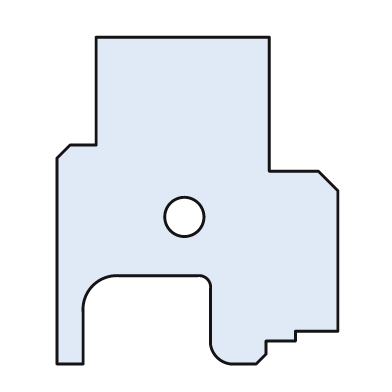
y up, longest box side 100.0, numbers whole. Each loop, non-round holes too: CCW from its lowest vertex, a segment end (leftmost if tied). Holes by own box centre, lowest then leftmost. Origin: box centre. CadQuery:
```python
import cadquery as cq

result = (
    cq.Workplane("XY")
    .moveTo(-43.0, -50.0)
    .lineTo(-35.0, -50.0)
    .lineTo(-35.0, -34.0)
    .threePointArc((-32.0, -26.0), (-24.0, -23.0))
    .lineTo(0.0, -23.0)
    .threePointArc((3.0, -24.0), (4.0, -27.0))
    .lineTo(4.0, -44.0)
    .threePointArc((6.0, -48.0), (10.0, -50.0))
    .lineTo(18.0, -50.0)
    .lineTo(21.0, -47.0)
    .lineTo(21.0, -43.0)
    .lineTo(30.0, -43.0)
    .lineTo(30.0, -40.0)
    .lineTo(43.0, -40.0)
    .lineTo(43.0, 3.0)
    .lineTo(37.0, 9.0)
    .lineTo(22.0, 9.0)
    .lineTo(22.0, 50.0)
    .lineTo(-31.0, 50.0)
    .lineTo(-31.0, 17.0)
    .lineTo(-39.0, 17.0)
    .lineTo(-43.0, 13.0)
    .close()
    .moveTo(-4.0, -5.0)
    .circle(6.0)
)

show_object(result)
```